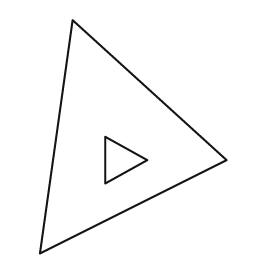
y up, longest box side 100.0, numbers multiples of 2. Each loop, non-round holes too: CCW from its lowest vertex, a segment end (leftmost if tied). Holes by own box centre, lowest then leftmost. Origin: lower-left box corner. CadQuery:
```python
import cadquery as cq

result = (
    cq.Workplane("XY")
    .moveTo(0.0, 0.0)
    .lineTo(80.0, 40.0)
    .lineTo(14.0, 100.0)
    .close()
    .moveTo(28.0, 30.0)
    .lineTo(46.0, 40.0)
    .lineTo(28.0, 50.0)
    .close()
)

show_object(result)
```